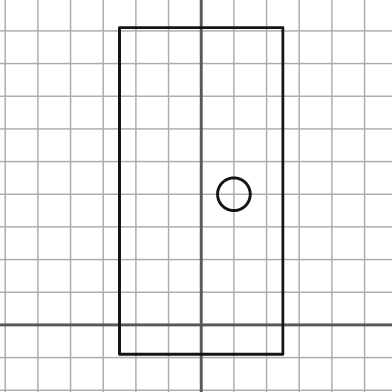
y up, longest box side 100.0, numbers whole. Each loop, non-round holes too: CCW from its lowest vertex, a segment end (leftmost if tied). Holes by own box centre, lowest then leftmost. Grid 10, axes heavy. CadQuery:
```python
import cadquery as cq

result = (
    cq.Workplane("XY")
    .moveTo(-25.0, -9.0)
    .lineTo(25.0, -9.0)
    .lineTo(25.0, 91.0)
    .lineTo(-25.0, 91.0)
    .close()
    .moveTo(10.0, 40.0)
    .circle(5.0)
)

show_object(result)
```